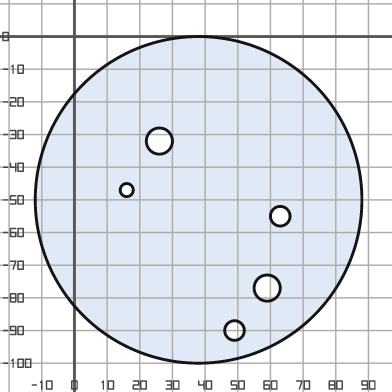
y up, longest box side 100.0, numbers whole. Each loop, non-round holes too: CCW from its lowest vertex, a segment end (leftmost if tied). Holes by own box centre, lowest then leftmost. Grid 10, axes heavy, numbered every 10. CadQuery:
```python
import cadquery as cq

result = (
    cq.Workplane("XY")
    .moveTo(38.0, -50.0)
    .circle(50.0)
    .moveTo(49.0, -90.0)
    .circle(3.0)
    .moveTo(59.0, -77.0)
    .circle(4.0)
    .moveTo(63.0, -55.0)
    .circle(3.0)
    .moveTo(16.0, -47.0)
    .circle(2.0)
    .moveTo(26.0, -32.0)
    .circle(4.0)
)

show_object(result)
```